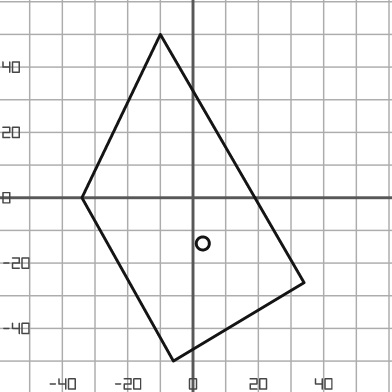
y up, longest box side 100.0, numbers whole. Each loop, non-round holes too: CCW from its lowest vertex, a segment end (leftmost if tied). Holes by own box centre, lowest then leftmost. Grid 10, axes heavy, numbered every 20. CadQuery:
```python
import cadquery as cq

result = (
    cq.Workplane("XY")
    .moveTo(-6.0, -50.0)
    .lineTo(34.0, -26.0)
    .lineTo(-10.0, 50.0)
    .lineTo(-34.0, 0.0)
    .close()
    .moveTo(3.0, -14.0)
    .circle(2.0)
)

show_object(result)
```